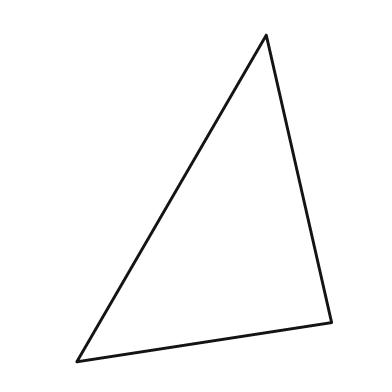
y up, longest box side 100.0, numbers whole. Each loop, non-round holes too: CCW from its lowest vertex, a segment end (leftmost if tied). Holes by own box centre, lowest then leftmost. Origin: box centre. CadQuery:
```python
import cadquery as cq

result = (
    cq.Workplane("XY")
    .moveTo(-39.0, -50.0)
    .lineTo(39.0, -38.0)
    .lineTo(19.0, 50.0)
    .close()
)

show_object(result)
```